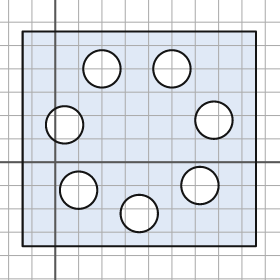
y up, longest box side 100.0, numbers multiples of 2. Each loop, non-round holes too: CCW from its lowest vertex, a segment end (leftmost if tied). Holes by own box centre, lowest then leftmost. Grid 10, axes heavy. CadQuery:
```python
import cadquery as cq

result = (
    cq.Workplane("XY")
    .moveTo(-14.0, -36.0)
    .lineTo(86.0, -36.0)
    .lineTo(86.0, 56.0)
    .lineTo(-14.0, 56.0)
    .close()
    .moveTo(36.0, -22.0)
    .circle(8.0)
    .moveTo(10.0, -12.0)
    .circle(8.0)
    .moveTo(62.0, -10.0)
    .circle(8.0)
    .moveTo(4.0, 16.0)
    .circle(8.0)
    .moveTo(68.0, 18.0)
    .circle(8.0)
    .moveTo(20.0, 40.0)
    .circle(8.0)
    .moveTo(50.0, 40.0)
    .circle(8.0)
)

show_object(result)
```